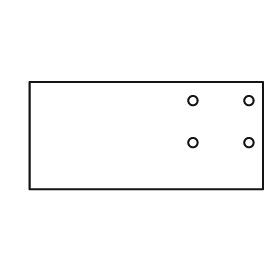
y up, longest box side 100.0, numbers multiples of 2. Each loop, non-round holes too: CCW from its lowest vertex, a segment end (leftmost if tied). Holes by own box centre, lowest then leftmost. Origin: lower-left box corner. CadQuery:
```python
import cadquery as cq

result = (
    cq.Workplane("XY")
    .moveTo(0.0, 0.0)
    .lineTo(100.0, 0.0)
    .lineTo(100.0, 46.0)
    .lineTo(0.0, 46.0)
    .close()
    .moveTo(70.0, 20.0)
    .circle(2.0)
    .moveTo(94.0, 20.0)
    .circle(2.0)
    .moveTo(70.0, 38.0)
    .circle(2.0)
    .moveTo(94.0, 38.0)
    .circle(2.0)
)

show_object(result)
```